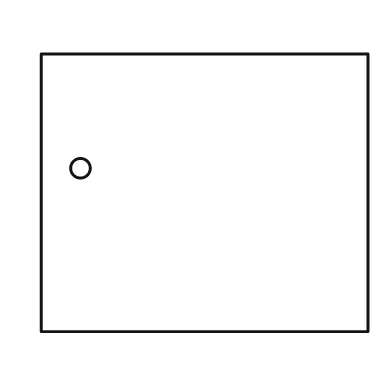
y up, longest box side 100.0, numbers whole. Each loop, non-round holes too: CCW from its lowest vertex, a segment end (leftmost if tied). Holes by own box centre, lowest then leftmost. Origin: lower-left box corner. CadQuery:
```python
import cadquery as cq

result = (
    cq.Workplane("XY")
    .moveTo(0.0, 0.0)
    .lineTo(100.0, 0.0)
    .lineTo(100.0, 85.0)
    .lineTo(0.0, 85.0)
    .close()
    .moveTo(12.0, 50.0)
    .circle(3.0)
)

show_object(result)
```